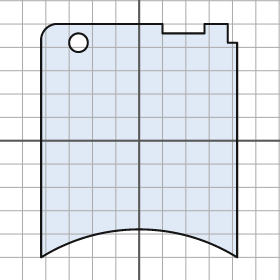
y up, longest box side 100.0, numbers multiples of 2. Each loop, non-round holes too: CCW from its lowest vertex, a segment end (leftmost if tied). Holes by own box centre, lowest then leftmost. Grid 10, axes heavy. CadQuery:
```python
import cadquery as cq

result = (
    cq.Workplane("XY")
    .moveTo(-42.0, -50.0)
    .threePointArc((0.0, -38.0), (42.0, -50.0))
    .lineTo(42.0, 42.0)
    .lineTo(38.0, 42.0)
    .lineTo(38.0, 50.0)
    .lineTo(28.0, 50.0)
    .lineTo(28.0, 46.0)
    .lineTo(10.0, 46.0)
    .lineTo(10.0, 50.0)
    .lineTo(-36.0, 50.0)
    .threePointArc((-40.0, 48.0), (-42.0, 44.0))
    .close()
    .moveTo(-26.0, 42.0)
    .circle(4.0)
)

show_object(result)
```